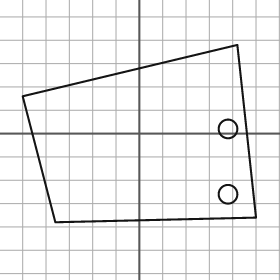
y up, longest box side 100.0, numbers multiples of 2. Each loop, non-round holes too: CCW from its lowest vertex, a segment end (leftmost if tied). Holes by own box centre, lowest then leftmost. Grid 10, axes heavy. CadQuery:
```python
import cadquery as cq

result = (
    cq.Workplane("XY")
    .moveTo(-36.0, -38.0)
    .lineTo(50.0, -36.0)
    .lineTo(42.0, 38.0)
    .lineTo(-50.0, 16.0)
    .close()
    .moveTo(38.0, -26.0)
    .circle(4.0)
    .moveTo(38.0, 2.0)
    .circle(4.0)
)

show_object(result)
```